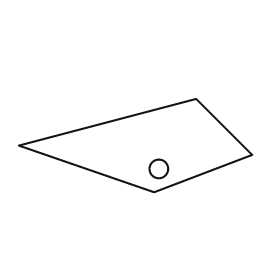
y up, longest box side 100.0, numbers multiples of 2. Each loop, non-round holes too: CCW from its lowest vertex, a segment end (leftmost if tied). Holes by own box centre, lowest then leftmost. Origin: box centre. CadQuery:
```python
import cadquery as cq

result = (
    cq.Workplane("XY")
    .moveTo(8.0, -20.0)
    .lineTo(50.0, -4.0)
    .lineTo(26.0, 20.0)
    .lineTo(-50.0, 0.0)
    .close()
    .moveTo(10.0, -10.0)
    .circle(4.0)
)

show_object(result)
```